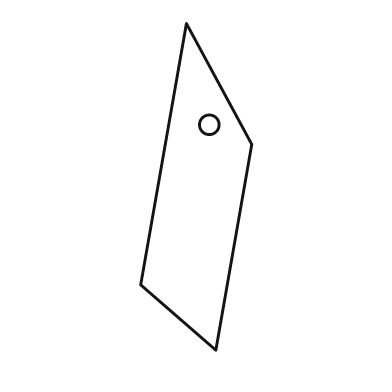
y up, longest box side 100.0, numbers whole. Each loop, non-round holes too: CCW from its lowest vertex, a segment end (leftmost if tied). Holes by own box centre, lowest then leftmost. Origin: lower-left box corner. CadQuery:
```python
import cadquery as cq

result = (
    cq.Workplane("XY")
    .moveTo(23.0, 0.0)
    .lineTo(34.0, 63.0)
    .lineTo(14.0, 100.0)
    .lineTo(0.0, 20.0)
    .close()
    .moveTo(21.0, 69.0)
    .circle(3.0)
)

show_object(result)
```